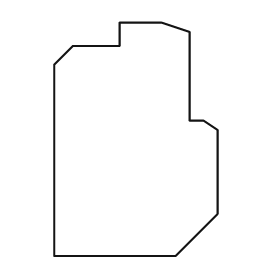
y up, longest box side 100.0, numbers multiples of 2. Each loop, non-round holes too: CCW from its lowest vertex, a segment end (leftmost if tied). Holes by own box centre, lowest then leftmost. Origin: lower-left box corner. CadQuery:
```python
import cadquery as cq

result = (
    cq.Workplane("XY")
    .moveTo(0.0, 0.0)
    .lineTo(52.0, 0.0)
    .lineTo(70.0, 18.0)
    .lineTo(70.0, 54.0)
    .lineTo(64.0, 58.0)
    .lineTo(58.0, 58.0)
    .lineTo(58.0, 96.0)
    .lineTo(46.0, 100.0)
    .lineTo(28.0, 100.0)
    .lineTo(28.0, 90.0)
    .lineTo(8.0, 90.0)
    .lineTo(0.0, 82.0)
    .close()
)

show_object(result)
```